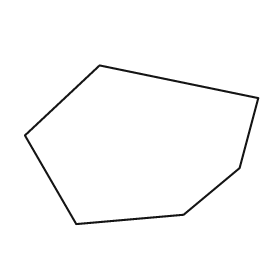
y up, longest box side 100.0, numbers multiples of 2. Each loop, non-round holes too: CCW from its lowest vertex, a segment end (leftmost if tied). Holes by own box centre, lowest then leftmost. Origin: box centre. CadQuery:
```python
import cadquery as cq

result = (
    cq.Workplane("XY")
    .moveTo(-28.0, -34.0)
    .lineTo(18.0, -30.0)
    .lineTo(42.0, -10.0)
    .lineTo(50.0, 20.0)
    .lineTo(-18.0, 34.0)
    .lineTo(-50.0, 4.0)
    .close()
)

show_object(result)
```